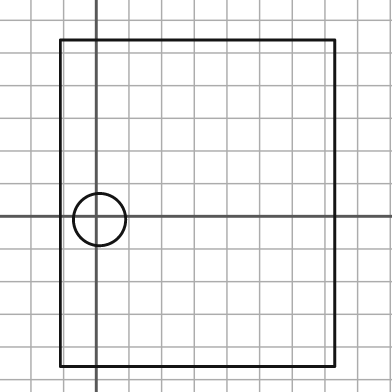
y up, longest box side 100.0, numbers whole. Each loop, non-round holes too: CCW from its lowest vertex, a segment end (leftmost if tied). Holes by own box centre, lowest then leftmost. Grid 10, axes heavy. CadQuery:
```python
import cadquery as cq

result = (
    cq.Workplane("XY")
    .moveTo(-11.0, -46.0)
    .lineTo(73.0, -46.0)
    .lineTo(73.0, 54.0)
    .lineTo(-11.0, 54.0)
    .close()
    .moveTo(1.0, -1.0)
    .circle(8.0)
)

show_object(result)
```